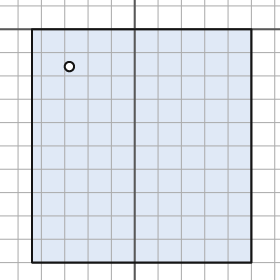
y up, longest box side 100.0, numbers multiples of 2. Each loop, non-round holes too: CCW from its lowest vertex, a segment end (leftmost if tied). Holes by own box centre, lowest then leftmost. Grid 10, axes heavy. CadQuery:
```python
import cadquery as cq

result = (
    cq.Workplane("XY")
    .moveTo(-44.0, -100.0)
    .lineTo(50.0, -100.0)
    .lineTo(50.0, 0.0)
    .lineTo(-44.0, 0.0)
    .close()
    .moveTo(-28.0, -16.0)
    .circle(2.0)
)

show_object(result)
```